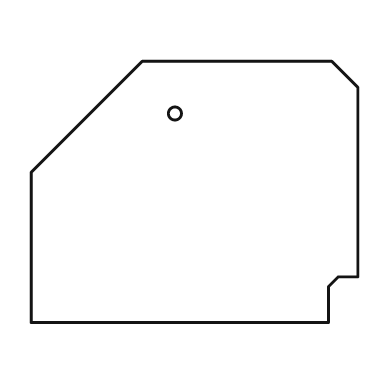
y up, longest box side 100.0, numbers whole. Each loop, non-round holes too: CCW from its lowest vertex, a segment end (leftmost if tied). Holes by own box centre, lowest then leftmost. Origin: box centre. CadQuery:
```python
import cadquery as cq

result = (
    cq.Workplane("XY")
    .moveTo(-50.0, -40.0)
    .lineTo(41.0, -40.0)
    .lineTo(41.0, -29.0)
    .lineTo(44.0, -26.0)
    .lineTo(50.0, -26.0)
    .lineTo(50.0, 32.0)
    .lineTo(42.0, 40.0)
    .lineTo(-16.0, 40.0)
    .lineTo(-50.0, 6.0)
    .close()
    .moveTo(-6.0, 24.0)
    .circle(2.0)
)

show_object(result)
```